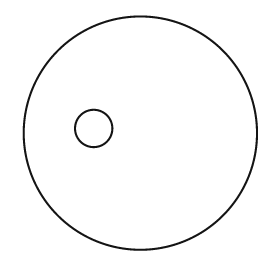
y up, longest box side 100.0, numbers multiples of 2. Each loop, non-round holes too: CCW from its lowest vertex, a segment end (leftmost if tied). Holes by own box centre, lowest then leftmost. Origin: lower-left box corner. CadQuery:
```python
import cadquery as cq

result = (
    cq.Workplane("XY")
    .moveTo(50.0, 50.0)
    .circle(50.0)
    .moveTo(30.0, 52.0)
    .circle(8.0)
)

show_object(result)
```